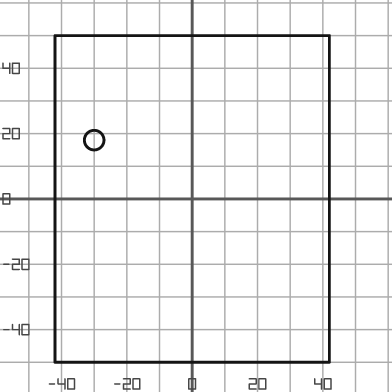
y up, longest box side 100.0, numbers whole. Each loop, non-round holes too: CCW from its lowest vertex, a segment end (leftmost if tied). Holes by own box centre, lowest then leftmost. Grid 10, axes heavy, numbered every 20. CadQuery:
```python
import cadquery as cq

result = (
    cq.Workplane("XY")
    .moveTo(-42.0, -50.0)
    .lineTo(42.0, -50.0)
    .lineTo(42.0, 50.0)
    .lineTo(-42.0, 50.0)
    .close()
    .moveTo(-30.0, 18.0)
    .circle(3.0)
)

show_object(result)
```